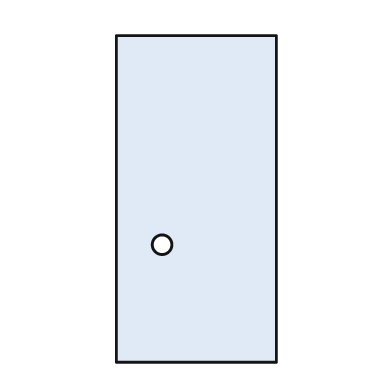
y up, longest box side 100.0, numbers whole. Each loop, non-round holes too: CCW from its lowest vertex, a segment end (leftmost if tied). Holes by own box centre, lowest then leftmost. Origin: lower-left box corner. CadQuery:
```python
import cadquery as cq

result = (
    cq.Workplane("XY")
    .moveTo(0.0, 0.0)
    .lineTo(49.0, 0.0)
    .lineTo(49.0, 100.0)
    .lineTo(0.0, 100.0)
    .close()
    .moveTo(14.0, 36.0)
    .circle(3.0)
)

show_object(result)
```